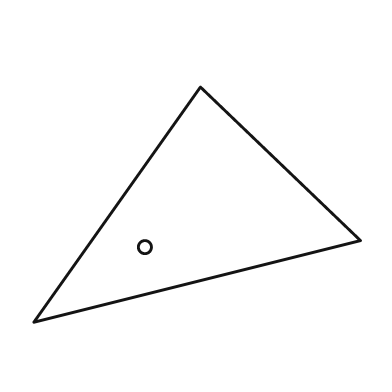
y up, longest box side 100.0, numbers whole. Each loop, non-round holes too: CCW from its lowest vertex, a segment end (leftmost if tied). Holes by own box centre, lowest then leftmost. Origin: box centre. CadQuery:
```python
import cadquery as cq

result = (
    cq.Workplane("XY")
    .moveTo(-50.0, -36.0)
    .lineTo(50.0, -11.0)
    .lineTo(1.0, 36.0)
    .close()
    .moveTo(-16.0, -13.0)
    .circle(2.0)
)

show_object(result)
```